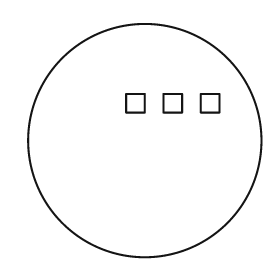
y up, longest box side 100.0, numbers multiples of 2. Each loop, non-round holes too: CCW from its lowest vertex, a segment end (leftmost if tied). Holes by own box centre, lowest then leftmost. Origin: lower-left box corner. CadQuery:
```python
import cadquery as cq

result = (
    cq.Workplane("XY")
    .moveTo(50.0, 50.0)
    .circle(50.0)
    .moveTo(42.0, 62.0)
    .lineTo(50.0, 62.0)
    .lineTo(50.0, 70.0)
    .lineTo(42.0, 70.0)
    .close()
    .moveTo(58.0, 62.0)
    .lineTo(66.0, 62.0)
    .lineTo(66.0, 70.0)
    .lineTo(58.0, 70.0)
    .close()
    .moveTo(74.0, 62.0)
    .lineTo(82.0, 62.0)
    .lineTo(82.0, 70.0)
    .lineTo(74.0, 70.0)
    .close()
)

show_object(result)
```